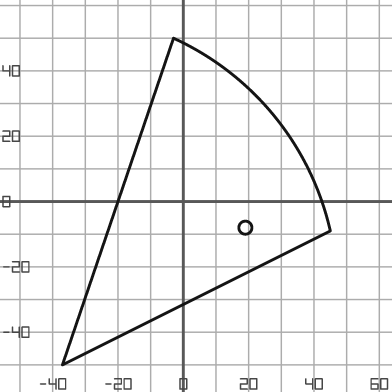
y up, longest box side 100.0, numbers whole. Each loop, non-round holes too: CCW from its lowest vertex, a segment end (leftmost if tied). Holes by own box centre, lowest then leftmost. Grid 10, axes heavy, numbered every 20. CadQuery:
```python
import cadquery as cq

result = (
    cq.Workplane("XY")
    .moveTo(-37.0, -50.0)
    .lineTo(45.0, -9.0)
    .threePointArc((28.0, 26.0), (-3.0, 50.0))
    .close()
    .moveTo(19.0, -8.0)
    .circle(2.0)
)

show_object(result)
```